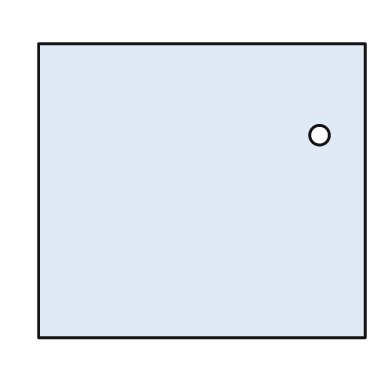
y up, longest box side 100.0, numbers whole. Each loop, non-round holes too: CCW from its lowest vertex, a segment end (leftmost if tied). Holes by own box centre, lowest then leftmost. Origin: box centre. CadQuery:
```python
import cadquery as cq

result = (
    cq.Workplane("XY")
    .moveTo(-50.0, -45.0)
    .lineTo(50.0, -45.0)
    .lineTo(50.0, 45.0)
    .lineTo(-50.0, 45.0)
    .close()
    .moveTo(36.0, 17.0)
    .circle(3.0)
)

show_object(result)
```